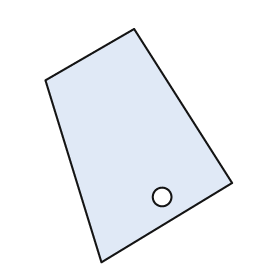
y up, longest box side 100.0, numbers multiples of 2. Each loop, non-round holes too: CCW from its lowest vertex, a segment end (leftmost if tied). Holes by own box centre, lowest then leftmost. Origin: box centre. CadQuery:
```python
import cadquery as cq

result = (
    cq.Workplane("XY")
    .moveTo(-16.0, -50.0)
    .lineTo(40.0, -16.0)
    .lineTo(-2.0, 50.0)
    .lineTo(-40.0, 28.0)
    .close()
    .moveTo(10.0, -22.0)
    .circle(4.0)
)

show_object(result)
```